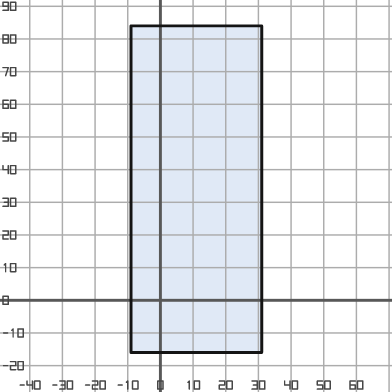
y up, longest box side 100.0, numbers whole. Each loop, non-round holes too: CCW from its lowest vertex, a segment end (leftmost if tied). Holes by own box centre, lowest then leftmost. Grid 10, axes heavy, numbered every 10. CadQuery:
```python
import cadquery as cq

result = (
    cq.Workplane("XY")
    .moveTo(-9.0, -16.0)
    .lineTo(31.0, -16.0)
    .lineTo(31.0, 84.0)
    .lineTo(-9.0, 84.0)
    .close()
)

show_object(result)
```